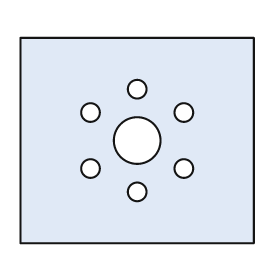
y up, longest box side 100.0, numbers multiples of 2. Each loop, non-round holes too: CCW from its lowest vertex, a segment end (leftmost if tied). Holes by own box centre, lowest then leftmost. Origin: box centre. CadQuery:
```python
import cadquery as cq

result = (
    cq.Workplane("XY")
    .moveTo(-50.0, -44.0)
    .lineTo(50.0, -44.0)
    .lineTo(50.0, 44.0)
    .lineTo(-50.0, 44.0)
    .close()
    .moveTo(0.0, -22.0)
    .circle(4.0)
    .moveTo(-20.0, -12.0)
    .circle(4.0)
    .moveTo(20.0, -12.0)
    .circle(4.0)
    .moveTo(0.0, 0.0)
    .circle(10.0)
    .moveTo(-20.0, 12.0)
    .circle(4.0)
    .moveTo(20.0, 12.0)
    .circle(4.0)
    .moveTo(0.0, 22.0)
    .circle(4.0)
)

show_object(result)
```